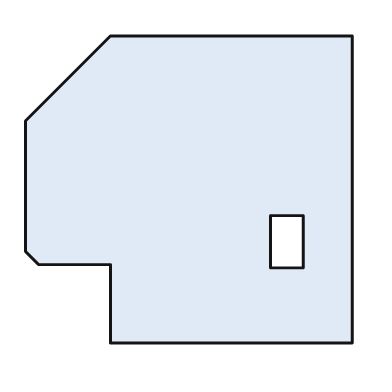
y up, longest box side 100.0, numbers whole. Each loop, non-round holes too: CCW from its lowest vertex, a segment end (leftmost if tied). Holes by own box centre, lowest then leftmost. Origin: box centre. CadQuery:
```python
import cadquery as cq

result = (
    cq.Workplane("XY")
    .moveTo(-24.0, -47.0)
    .lineTo(50.0, -47.0)
    .lineTo(50.0, 47.0)
    .lineTo(-24.0, 47.0)
    .lineTo(-50.0, 21.0)
    .lineTo(-50.0, -19.0)
    .lineTo(-46.0, -23.0)
    .lineTo(-24.0, -23.0)
    .close()
    .moveTo(25.0, -24.0)
    .lineTo(35.0, -24.0)
    .lineTo(35.0, -8.0)
    .lineTo(25.0, -8.0)
    .close()
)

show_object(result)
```